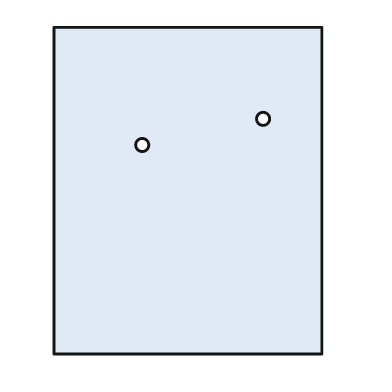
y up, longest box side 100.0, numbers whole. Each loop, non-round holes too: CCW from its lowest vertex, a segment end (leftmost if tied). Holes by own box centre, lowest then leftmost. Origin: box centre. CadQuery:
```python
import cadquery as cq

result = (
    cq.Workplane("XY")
    .moveTo(-41.0, -50.0)
    .lineTo(41.0, -50.0)
    .lineTo(41.0, 50.0)
    .lineTo(-41.0, 50.0)
    .close()
    .moveTo(-14.0, 14.0)
    .circle(2.0)
    .moveTo(23.0, 22.0)
    .circle(2.0)
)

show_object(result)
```